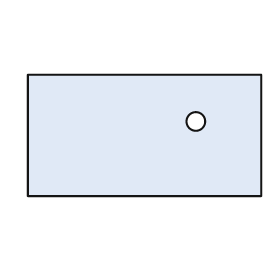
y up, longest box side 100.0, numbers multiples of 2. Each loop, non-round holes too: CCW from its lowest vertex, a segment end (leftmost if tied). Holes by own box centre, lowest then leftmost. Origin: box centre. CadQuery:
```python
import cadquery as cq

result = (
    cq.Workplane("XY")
    .moveTo(-50.0, -26.0)
    .lineTo(50.0, -26.0)
    .lineTo(50.0, 26.0)
    .lineTo(-50.0, 26.0)
    .close()
    .moveTo(22.0, 6.0)
    .circle(4.0)
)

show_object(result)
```